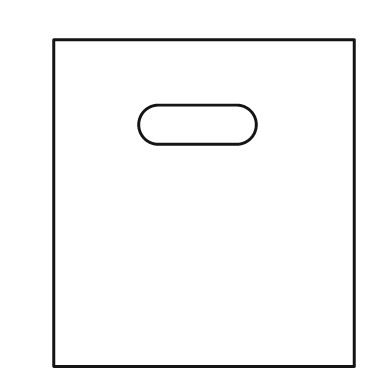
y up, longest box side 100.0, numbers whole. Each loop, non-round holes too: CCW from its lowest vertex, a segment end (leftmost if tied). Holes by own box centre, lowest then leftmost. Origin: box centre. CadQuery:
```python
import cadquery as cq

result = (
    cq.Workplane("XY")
    .moveTo(-46.0, -50.0)
    .lineTo(46.0, -50.0)
    .lineTo(46.0, 50.0)
    .lineTo(-46.0, 50.0)
    .close()
    .moveTo(-14.0, 18.0)
    .lineTo(10.0, 18.0)
    .threePointArc((16.0, 24.0), (10.0, 30.0))
    .lineTo(-14.0, 30.0)
    .threePointArc((-20.0, 24.0), (-14.0, 18.0))
    .close()
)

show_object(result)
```